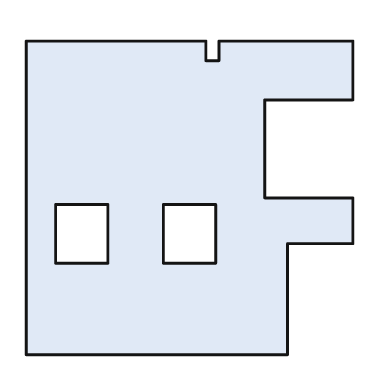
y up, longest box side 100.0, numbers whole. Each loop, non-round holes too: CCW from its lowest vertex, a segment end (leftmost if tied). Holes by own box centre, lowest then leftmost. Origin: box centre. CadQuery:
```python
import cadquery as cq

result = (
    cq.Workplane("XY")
    .moveTo(-50.0, -48.0)
    .lineTo(30.0, -48.0)
    .lineTo(30.0, -14.0)
    .lineTo(50.0, -14.0)
    .lineTo(50.0, 0.0)
    .lineTo(23.0, 0.0)
    .lineTo(23.0, 30.0)
    .lineTo(50.0, 30.0)
    .lineTo(50.0, 48.0)
    .lineTo(9.0, 48.0)
    .lineTo(9.0, 42.0)
    .lineTo(5.0, 42.0)
    .lineTo(5.0, 48.0)
    .lineTo(-50.0, 48.0)
    .close()
    .moveTo(-41.0, -20.0)
    .lineTo(-25.0, -20.0)
    .lineTo(-25.0, -2.0)
    .lineTo(-41.0, -2.0)
    .close()
    .moveTo(-8.0, -20.0)
    .lineTo(8.0, -20.0)
    .lineTo(8.0, -2.0)
    .lineTo(-8.0, -2.0)
    .close()
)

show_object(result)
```